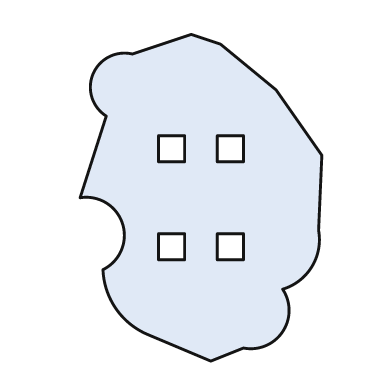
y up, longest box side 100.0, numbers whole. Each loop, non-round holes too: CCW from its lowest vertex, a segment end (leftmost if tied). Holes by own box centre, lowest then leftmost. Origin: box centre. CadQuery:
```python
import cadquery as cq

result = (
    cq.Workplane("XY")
    .moveTo(3.0, -50.0)
    .lineTo(13.0, -46.0)
    .threePointArc((25.0, -41.0), (25.0, -28.0))
    .threePointArc((34.0, -21.0), (36.0, -10.0))
    .lineTo(37.0, 13.0)
    .lineTo(23.0, 33.0)
    .lineTo(6.0, 47.0)
    .lineTo(-3.0, 50.0)
    .lineTo(-21.0, 44.0)
    .threePointArc((-33.0, 38.0), (-29.0, 25.0))
    .lineTo(-37.0, 0.0)
    .threePointArc((-24.0, -8.0), (-30.0, -22.0))
    .threePointArc((-26.0, -34.0), (-16.0, -42.0))
    .close()
    .moveTo(-13.0, -19.0)
    .lineTo(-5.0, -19.0)
    .lineTo(-5.0, -11.0)
    .lineTo(-13.0, -11.0)
    .close()
    .moveTo(5.0, -19.0)
    .lineTo(13.0, -19.0)
    .lineTo(13.0, -11.0)
    .lineTo(5.0, -11.0)
    .close()
    .moveTo(-13.0, 11.0)
    .lineTo(-5.0, 11.0)
    .lineTo(-5.0, 19.0)
    .lineTo(-13.0, 19.0)
    .close()
    .moveTo(5.0, 11.0)
    .lineTo(13.0, 11.0)
    .lineTo(13.0, 19.0)
    .lineTo(5.0, 19.0)
    .close()
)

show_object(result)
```